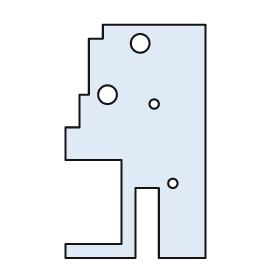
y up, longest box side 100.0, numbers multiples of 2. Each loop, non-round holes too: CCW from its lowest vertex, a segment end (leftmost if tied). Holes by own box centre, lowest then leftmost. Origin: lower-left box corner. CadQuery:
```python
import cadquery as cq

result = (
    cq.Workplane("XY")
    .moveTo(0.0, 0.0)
    .lineTo(30.0, 0.0)
    .lineTo(30.0, 30.0)
    .lineTo(40.0, 30.0)
    .lineTo(40.0, 0.0)
    .lineTo(60.0, 0.0)
    .lineTo(60.0, 100.0)
    .lineTo(16.0, 100.0)
    .lineTo(16.0, 94.0)
    .lineTo(10.0, 94.0)
    .lineTo(10.0, 70.0)
    .lineTo(6.0, 70.0)
    .lineTo(6.0, 56.0)
    .lineTo(0.0, 56.0)
    .lineTo(0.0, 42.0)
    .lineTo(24.0, 42.0)
    .lineTo(24.0, 6.0)
    .lineTo(0.0, 6.0)
    .close()
    .moveTo(46.0, 32.0)
    .circle(2.0)
    .moveTo(38.0, 66.0)
    .circle(2.0)
    .moveTo(18.0, 70.0)
    .circle(4.0)
    .moveTo(32.0, 92.0)
    .circle(4.0)
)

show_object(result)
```